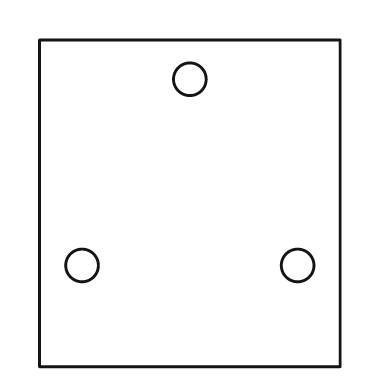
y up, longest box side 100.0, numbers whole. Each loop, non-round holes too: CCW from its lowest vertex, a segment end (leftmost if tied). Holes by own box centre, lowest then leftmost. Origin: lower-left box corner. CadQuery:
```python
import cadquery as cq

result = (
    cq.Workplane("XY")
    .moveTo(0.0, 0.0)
    .lineTo(92.0, 0.0)
    .lineTo(92.0, 100.0)
    .lineTo(0.0, 100.0)
    .close()
    .moveTo(13.0, 31.0)
    .circle(5.0)
    .moveTo(79.0, 31.0)
    .circle(5.0)
    .moveTo(46.0, 88.0)
    .circle(5.0)
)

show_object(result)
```